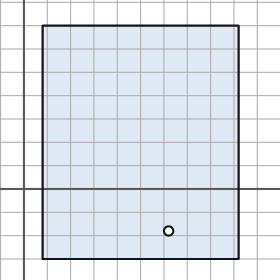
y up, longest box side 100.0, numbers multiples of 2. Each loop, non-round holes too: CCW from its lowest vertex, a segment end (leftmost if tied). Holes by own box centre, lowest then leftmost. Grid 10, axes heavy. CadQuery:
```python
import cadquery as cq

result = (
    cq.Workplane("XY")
    .moveTo(8.0, -30.0)
    .lineTo(92.0, -30.0)
    .lineTo(92.0, 70.0)
    .lineTo(8.0, 70.0)
    .close()
    .moveTo(62.0, -18.0)
    .circle(2.0)
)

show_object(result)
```